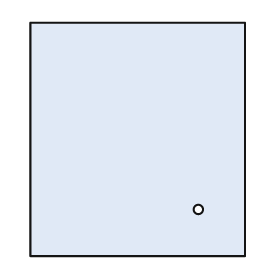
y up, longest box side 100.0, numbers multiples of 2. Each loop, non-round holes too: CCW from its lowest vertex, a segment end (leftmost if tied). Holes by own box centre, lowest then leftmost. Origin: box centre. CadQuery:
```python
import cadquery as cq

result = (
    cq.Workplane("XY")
    .moveTo(-46.0, -50.0)
    .lineTo(46.0, -50.0)
    .lineTo(46.0, 50.0)
    .lineTo(-46.0, 50.0)
    .close()
    .moveTo(26.0, -30.0)
    .circle(2.0)
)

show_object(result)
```